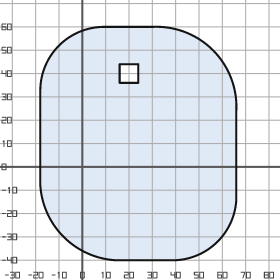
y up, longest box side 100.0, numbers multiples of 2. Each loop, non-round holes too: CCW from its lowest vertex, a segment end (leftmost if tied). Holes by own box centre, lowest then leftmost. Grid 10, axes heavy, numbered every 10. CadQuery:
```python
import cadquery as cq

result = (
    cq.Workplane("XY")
    .moveTo(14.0, -40.0)
    .lineTo(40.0, -40.0)
    .threePointArc((58.0, -32.0), (66.0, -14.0))
    .lineTo(66.0, 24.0)
    .threePointArc((56.0, 50.0), (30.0, 60.0))
    .lineTo(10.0, 60.0)
    .threePointArc((-10.0, 52.0), (-18.0, 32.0))
    .lineTo(-18.0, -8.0)
    .threePointArc((-8.0, -30.0), (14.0, -40.0))
    .close()
    .moveTo(16.0, 36.0)
    .lineTo(24.0, 36.0)
    .lineTo(24.0, 44.0)
    .lineTo(16.0, 44.0)
    .close()
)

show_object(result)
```